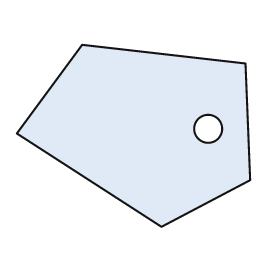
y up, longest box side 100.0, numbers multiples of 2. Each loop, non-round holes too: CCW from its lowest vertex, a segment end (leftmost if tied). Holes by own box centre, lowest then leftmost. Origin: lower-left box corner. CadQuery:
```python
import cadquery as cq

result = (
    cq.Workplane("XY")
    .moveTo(62.0, 0.0)
    .lineTo(100.0, 20.0)
    .lineTo(98.0, 70.0)
    .lineTo(28.0, 78.0)
    .lineTo(0.0, 40.0)
    .close()
    .moveTo(82.0, 42.0)
    .circle(6.0)
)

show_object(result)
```